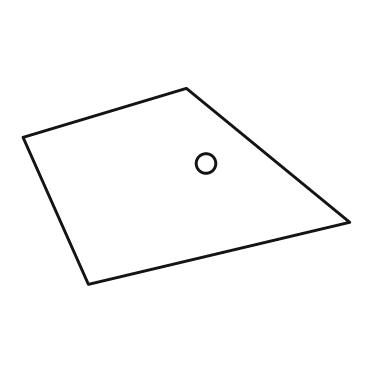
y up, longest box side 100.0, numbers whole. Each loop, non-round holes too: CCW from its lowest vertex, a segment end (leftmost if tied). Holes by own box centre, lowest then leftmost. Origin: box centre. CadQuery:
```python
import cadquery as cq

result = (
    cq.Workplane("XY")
    .moveTo(-30.0, -30.0)
    .lineTo(50.0, -11.0)
    .lineTo(0.0, 30.0)
    .lineTo(-50.0, 15.0)
    .close()
    .moveTo(6.0, 7.0)
    .circle(3.0)
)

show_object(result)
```